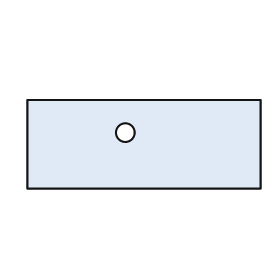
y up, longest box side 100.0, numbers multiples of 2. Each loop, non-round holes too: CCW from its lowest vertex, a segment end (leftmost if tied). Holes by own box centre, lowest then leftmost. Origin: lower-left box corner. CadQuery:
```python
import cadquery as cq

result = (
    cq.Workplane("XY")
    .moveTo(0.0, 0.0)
    .lineTo(100.0, 0.0)
    .lineTo(100.0, 38.0)
    .lineTo(0.0, 38.0)
    .close()
    .moveTo(42.0, 24.0)
    .circle(4.0)
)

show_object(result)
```